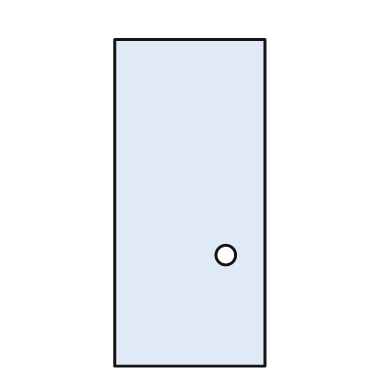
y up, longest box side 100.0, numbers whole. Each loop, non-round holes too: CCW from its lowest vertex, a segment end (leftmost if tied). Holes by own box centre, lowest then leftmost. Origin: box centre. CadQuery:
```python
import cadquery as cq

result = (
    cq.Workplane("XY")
    .moveTo(-23.0, -50.0)
    .lineTo(23.0, -50.0)
    .lineTo(23.0, 50.0)
    .lineTo(-23.0, 50.0)
    .close()
    .moveTo(11.0, -16.0)
    .circle(3.0)
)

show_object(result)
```